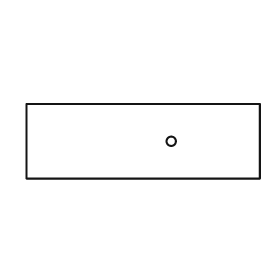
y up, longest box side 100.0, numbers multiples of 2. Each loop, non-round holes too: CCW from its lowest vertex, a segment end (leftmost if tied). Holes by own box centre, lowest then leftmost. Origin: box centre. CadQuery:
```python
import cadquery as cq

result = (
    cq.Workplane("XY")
    .moveTo(-50.0, -16.0)
    .lineTo(50.0, -16.0)
    .lineTo(50.0, 16.0)
    .lineTo(-50.0, 16.0)
    .close()
    .moveTo(12.0, 0.0)
    .circle(2.0)
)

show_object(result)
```